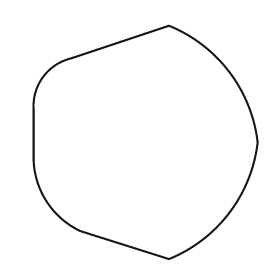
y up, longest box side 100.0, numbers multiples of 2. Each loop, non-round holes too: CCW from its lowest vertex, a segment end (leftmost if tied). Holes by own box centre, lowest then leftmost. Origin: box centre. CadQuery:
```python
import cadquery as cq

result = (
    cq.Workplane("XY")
    .moveTo(10.0, -50.0)
    .threePointArc((36.0, -30.0), (48.0, 0.0))
    .threePointArc((36.0, 30.0), (10.0, 50.0))
    .lineTo(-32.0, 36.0)
    .threePointArc((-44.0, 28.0), (-48.0, 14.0))
    .lineTo(-48.0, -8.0)
    .threePointArc((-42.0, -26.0), (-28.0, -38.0))
    .close()
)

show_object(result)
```